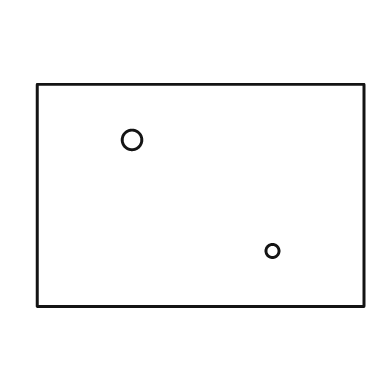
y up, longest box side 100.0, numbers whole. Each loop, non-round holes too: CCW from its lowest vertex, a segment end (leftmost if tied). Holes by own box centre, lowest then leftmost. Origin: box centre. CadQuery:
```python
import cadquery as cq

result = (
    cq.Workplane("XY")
    .moveTo(-50.0, -34.0)
    .lineTo(50.0, -34.0)
    .lineTo(50.0, 34.0)
    .lineTo(-50.0, 34.0)
    .close()
    .moveTo(22.0, -17.0)
    .circle(2.0)
    .moveTo(-21.0, 17.0)
    .circle(3.0)
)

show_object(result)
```